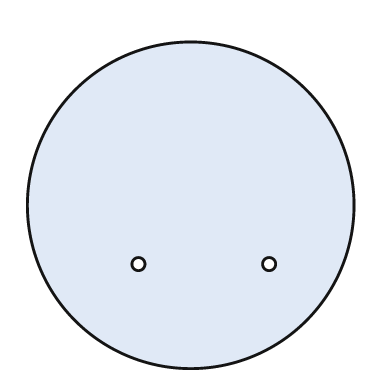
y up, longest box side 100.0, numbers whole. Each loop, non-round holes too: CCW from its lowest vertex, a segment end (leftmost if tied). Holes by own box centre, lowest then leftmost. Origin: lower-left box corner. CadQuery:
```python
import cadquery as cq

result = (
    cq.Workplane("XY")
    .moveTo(50.0, 50.0)
    .circle(50.0)
    .moveTo(34.0, 32.0)
    .circle(2.0)
    .moveTo(74.0, 32.0)
    .circle(2.0)
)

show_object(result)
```